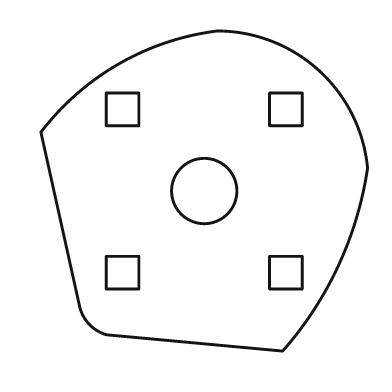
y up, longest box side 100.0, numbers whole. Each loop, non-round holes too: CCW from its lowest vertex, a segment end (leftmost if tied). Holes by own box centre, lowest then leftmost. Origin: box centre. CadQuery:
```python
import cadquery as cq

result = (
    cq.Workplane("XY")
    .moveTo(24.0, -49.0)
    .threePointArc((41.0, -23.0), (50.0, 7.0))
    .threePointArc((35.0, 37.0), (4.0, 49.0))
    .threePointArc((-26.0, 39.0), (-50.0, 18.0))
    .lineTo(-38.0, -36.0)
    .threePointArc((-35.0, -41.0), (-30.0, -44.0))
    .close()
    .moveTo(-30.0, -30.0)
    .lineTo(-20.0, -30.0)
    .lineTo(-20.0, -20.0)
    .lineTo(-30.0, -20.0)
    .close()
    .moveTo(20.0, -30.0)
    .lineTo(30.0, -30.0)
    .lineTo(30.0, -20.0)
    .lineTo(20.0, -20.0)
    .close()
    .moveTo(0.0, 0.0)
    .circle(10.0)
    .moveTo(-30.0, 20.0)
    .lineTo(-20.0, 20.0)
    .lineTo(-20.0, 30.0)
    .lineTo(-30.0, 30.0)
    .close()
    .moveTo(20.0, 20.0)
    .lineTo(30.0, 20.0)
    .lineTo(30.0, 30.0)
    .lineTo(20.0, 30.0)
    .close()
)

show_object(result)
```